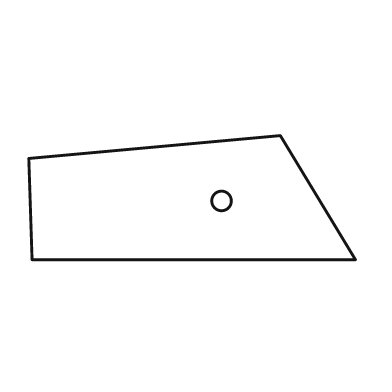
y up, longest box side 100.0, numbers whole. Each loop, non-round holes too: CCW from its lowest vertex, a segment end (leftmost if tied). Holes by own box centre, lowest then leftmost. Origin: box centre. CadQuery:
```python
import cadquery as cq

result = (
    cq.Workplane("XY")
    .moveTo(-49.0, -19.0)
    .lineTo(50.0, -19.0)
    .lineTo(27.0, 19.0)
    .lineTo(-50.0, 12.0)
    .close()
    .moveTo(9.0, -1.0)
    .circle(3.0)
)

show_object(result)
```